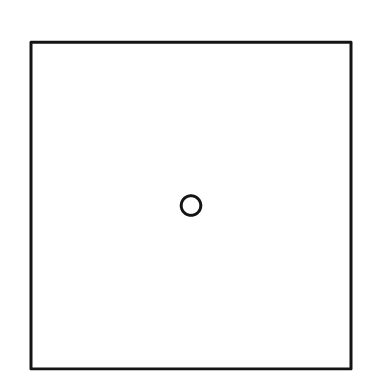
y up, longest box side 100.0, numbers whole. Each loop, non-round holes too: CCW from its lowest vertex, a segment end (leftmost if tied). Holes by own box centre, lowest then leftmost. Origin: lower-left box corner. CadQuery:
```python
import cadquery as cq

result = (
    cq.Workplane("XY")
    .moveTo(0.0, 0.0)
    .lineTo(98.0, 0.0)
    .lineTo(98.0, 100.0)
    .lineTo(0.0, 100.0)
    .close()
    .moveTo(49.0, 50.0)
    .circle(3.0)
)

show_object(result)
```